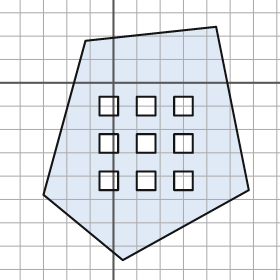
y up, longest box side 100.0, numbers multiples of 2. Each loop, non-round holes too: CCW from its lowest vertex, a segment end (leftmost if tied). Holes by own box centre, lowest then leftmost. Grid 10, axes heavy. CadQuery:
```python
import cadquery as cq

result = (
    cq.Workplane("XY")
    .moveTo(4.0, -76.0)
    .lineTo(58.0, -46.0)
    .lineTo(44.0, 24.0)
    .lineTo(-12.0, 18.0)
    .lineTo(-30.0, -48.0)
    .close()
    .moveTo(-6.0, -46.0)
    .lineTo(2.0, -46.0)
    .lineTo(2.0, -38.0)
    .lineTo(-6.0, -38.0)
    .close()
    .moveTo(10.0, -46.0)
    .lineTo(18.0, -46.0)
    .lineTo(18.0, -38.0)
    .lineTo(10.0, -38.0)
    .close()
    .moveTo(26.0, -46.0)
    .lineTo(34.0, -46.0)
    .lineTo(34.0, -38.0)
    .lineTo(26.0, -38.0)
    .close()
    .moveTo(-6.0, -30.0)
    .lineTo(2.0, -30.0)
    .lineTo(2.0, -22.0)
    .lineTo(-6.0, -22.0)
    .close()
    .moveTo(10.0, -30.0)
    .lineTo(18.0, -30.0)
    .lineTo(18.0, -22.0)
    .lineTo(10.0, -22.0)
    .close()
    .moveTo(26.0, -30.0)
    .lineTo(34.0, -30.0)
    .lineTo(34.0, -22.0)
    .lineTo(26.0, -22.0)
    .close()
    .moveTo(-6.0, -14.0)
    .lineTo(2.0, -14.0)
    .lineTo(2.0, -6.0)
    .lineTo(-6.0, -6.0)
    .close()
    .moveTo(10.0, -14.0)
    .lineTo(18.0, -14.0)
    .lineTo(18.0, -6.0)
    .lineTo(10.0, -6.0)
    .close()
    .moveTo(26.0, -14.0)
    .lineTo(34.0, -14.0)
    .lineTo(34.0, -6.0)
    .lineTo(26.0, -6.0)
    .close()
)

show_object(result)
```